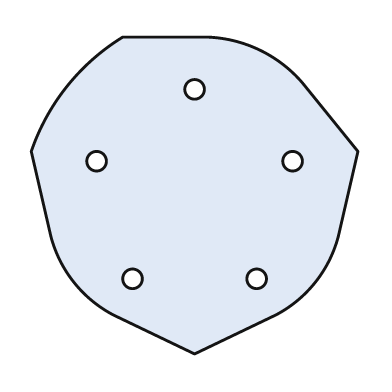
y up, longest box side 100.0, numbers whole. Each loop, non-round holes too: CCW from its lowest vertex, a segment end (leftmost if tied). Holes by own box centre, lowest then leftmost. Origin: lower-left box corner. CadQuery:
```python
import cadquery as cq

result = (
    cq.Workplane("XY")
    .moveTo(50.0, 0.0)
    .lineTo(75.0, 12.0)
    .threePointArc((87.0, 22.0), (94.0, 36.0))
    .lineTo(100.0, 62.0)
    .lineTo(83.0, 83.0)
    .threePointArc((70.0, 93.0), (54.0, 97.0))
    .lineTo(28.0, 97.0)
    .threePointArc((11.0, 82.0), (0.0, 62.0))
    .lineTo(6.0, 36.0)
    .threePointArc((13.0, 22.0), (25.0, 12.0))
    .close()
    .moveTo(31.0, 23.0)
    .circle(3.0)
    .moveTo(69.0, 23.0)
    .circle(3.0)
    .moveTo(20.0, 59.0)
    .circle(3.0)
    .moveTo(80.0, 59.0)
    .circle(3.0)
    .moveTo(50.0, 81.0)
    .circle(3.0)
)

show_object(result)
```